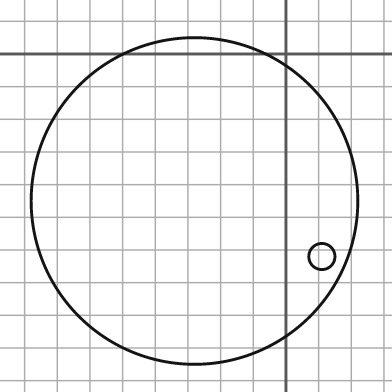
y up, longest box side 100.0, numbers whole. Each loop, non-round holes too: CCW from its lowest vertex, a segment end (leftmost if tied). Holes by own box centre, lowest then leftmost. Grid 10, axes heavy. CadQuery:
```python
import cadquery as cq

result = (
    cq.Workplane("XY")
    .moveTo(-28.0, -45.0)
    .circle(50.0)
    .moveTo(11.0, -62.0)
    .circle(4.0)
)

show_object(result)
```